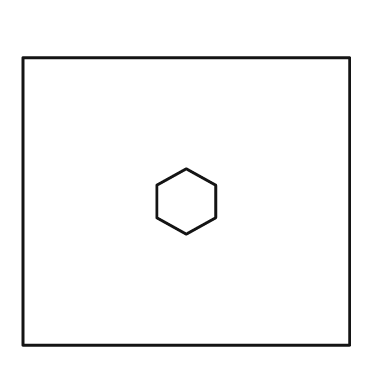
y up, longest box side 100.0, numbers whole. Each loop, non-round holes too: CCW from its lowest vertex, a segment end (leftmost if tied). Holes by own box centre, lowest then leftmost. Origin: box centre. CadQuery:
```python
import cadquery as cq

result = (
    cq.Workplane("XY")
    .moveTo(-50.0, -44.0)
    .lineTo(50.0, -44.0)
    .lineTo(50.0, 44.0)
    .lineTo(-50.0, 44.0)
    .close()
    .moveTo(0.0, -10.0)
    .lineTo(9.0, -5.0)
    .lineTo(9.0, 5.0)
    .lineTo(0.0, 10.0)
    .lineTo(-9.0, 5.0)
    .lineTo(-9.0, -5.0)
    .close()
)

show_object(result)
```